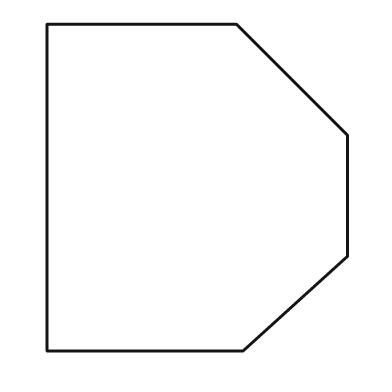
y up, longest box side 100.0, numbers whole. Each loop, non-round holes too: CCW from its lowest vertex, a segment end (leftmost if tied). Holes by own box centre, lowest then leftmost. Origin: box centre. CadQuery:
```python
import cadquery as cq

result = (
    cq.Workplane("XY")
    .moveTo(-46.0, -50.0)
    .lineTo(14.0, -50.0)
    .lineTo(46.0, -21.0)
    .lineTo(46.0, 16.0)
    .lineTo(12.0, 50.0)
    .lineTo(-46.0, 50.0)
    .close()
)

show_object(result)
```